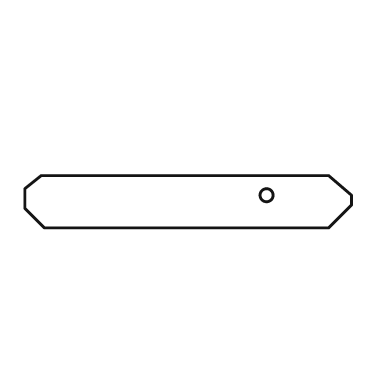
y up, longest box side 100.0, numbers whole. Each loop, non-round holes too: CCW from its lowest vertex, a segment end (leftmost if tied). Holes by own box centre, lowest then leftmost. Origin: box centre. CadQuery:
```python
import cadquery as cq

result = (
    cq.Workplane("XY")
    .moveTo(-44.0, -8.0)
    .lineTo(43.0, -8.0)
    .lineTo(50.0, -1.0)
    .lineTo(50.0, 2.0)
    .lineTo(43.0, 8.0)
    .lineTo(-45.0, 8.0)
    .lineTo(-50.0, 4.0)
    .lineTo(-50.0, -2.0)
    .close()
    .moveTo(24.0, 2.0)
    .circle(2.0)
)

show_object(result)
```